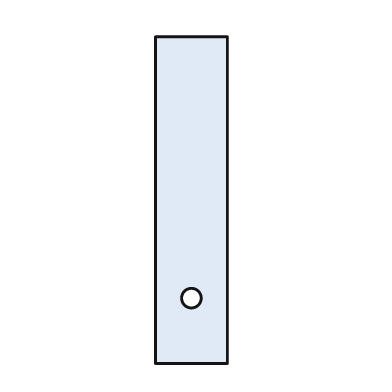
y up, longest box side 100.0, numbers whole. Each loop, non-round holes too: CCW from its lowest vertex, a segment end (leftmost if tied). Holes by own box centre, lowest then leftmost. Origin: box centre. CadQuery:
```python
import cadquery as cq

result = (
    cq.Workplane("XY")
    .moveTo(-11.0, -50.0)
    .lineTo(11.0, -50.0)
    .lineTo(11.0, 50.0)
    .lineTo(-11.0, 50.0)
    .close()
    .moveTo(0.0, -30.0)
    .circle(3.0)
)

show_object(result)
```